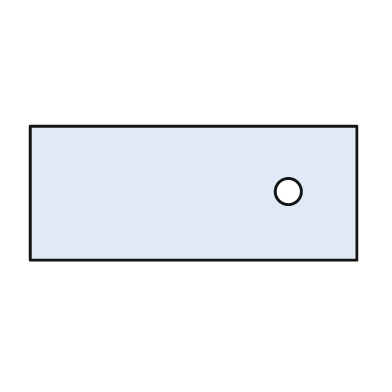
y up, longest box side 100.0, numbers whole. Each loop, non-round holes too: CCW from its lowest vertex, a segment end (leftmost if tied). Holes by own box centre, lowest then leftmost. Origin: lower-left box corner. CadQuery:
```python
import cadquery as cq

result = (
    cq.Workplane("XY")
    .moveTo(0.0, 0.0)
    .lineTo(100.0, 0.0)
    .lineTo(100.0, 41.0)
    .lineTo(0.0, 41.0)
    .close()
    .moveTo(79.0, 21.0)
    .circle(4.0)
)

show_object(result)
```